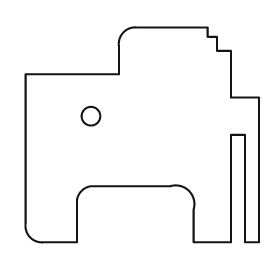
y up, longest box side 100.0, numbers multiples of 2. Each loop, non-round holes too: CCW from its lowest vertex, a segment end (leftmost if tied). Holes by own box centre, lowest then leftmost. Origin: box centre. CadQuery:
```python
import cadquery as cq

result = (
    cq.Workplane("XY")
    .moveTo(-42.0, -46.0)
    .lineTo(-28.0, -46.0)
    .lineTo(-28.0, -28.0)
    .threePointArc((-26.0, -24.0), (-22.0, -22.0))
    .lineTo(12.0, -22.0)
    .threePointArc((20.0, -24.0), (22.0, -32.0))
    .lineTo(22.0, -46.0)
    .lineTo(38.0, -46.0)
    .lineTo(38.0, 0.0)
    .lineTo(44.0, 0.0)
    .lineTo(44.0, -46.0)
    .lineTo(50.0, -46.0)
    .lineTo(50.0, 16.0)
    .lineTo(38.0, 16.0)
    .lineTo(38.0, 36.0)
    .lineTo(32.0, 36.0)
    .lineTo(32.0, 42.0)
    .lineTo(28.0, 42.0)
    .lineTo(28.0, 46.0)
    .lineTo(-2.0, 46.0)
    .threePointArc((-8.0, 44.0), (-10.0, 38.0))
    .lineTo(-10.0, 26.0)
    .lineTo(-50.0, 26.0)
    .lineTo(-50.0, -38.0)
    .threePointArc((-48.0, -44.0), (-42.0, -46.0))
    .close()
    .moveTo(-22.0, 8.0)
    .circle(4.0)
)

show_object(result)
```